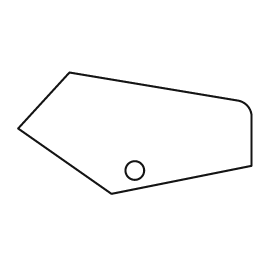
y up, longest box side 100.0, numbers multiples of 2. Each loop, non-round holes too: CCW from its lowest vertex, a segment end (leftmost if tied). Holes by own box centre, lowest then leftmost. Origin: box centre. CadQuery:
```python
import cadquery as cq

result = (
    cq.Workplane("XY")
    .moveTo(-10.0, -26.0)
    .lineTo(50.0, -14.0)
    .lineTo(50.0, 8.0)
    .threePointArc((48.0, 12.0), (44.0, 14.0))
    .lineTo(-28.0, 26.0)
    .lineTo(-50.0, 2.0)
    .close()
    .moveTo(0.0, -16.0)
    .circle(4.0)
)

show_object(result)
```